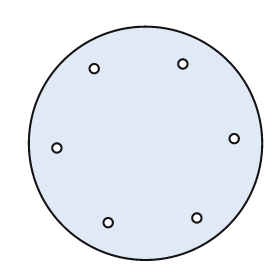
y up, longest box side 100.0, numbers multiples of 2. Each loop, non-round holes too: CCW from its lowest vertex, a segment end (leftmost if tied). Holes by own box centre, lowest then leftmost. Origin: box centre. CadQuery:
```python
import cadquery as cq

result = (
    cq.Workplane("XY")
    .moveTo(0.0, 0.0)
    .circle(50.0)
    .moveTo(-16.0, -34.0)
    .circle(2.0)
    .moveTo(22.0, -32.0)
    .circle(2.0)
    .moveTo(-38.0, -2.0)
    .circle(2.0)
    .moveTo(38.0, 2.0)
    .circle(2.0)
    .moveTo(-22.0, 32.0)
    .circle(2.0)
    .moveTo(16.0, 34.0)
    .circle(2.0)
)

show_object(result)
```